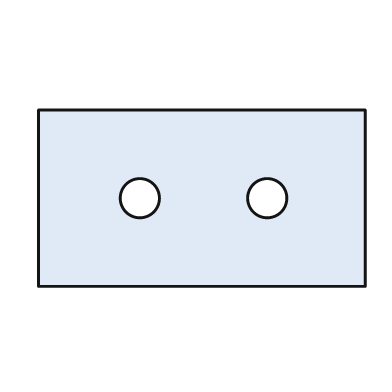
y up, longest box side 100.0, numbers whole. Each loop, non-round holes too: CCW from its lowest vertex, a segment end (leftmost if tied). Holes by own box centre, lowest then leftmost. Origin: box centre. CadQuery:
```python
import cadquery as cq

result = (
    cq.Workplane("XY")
    .moveTo(-50.0, -27.0)
    .lineTo(50.0, -27.0)
    .lineTo(50.0, 27.0)
    .lineTo(-50.0, 27.0)
    .close()
    .moveTo(-19.0, 0.0)
    .circle(6.0)
    .moveTo(20.0, 0.0)
    .circle(6.0)
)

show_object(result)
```